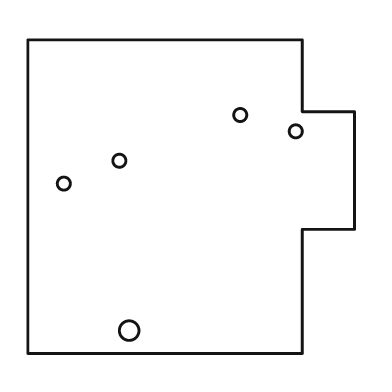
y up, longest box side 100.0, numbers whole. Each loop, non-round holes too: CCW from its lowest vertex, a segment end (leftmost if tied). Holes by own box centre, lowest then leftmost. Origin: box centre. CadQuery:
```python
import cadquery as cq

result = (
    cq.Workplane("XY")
    .moveTo(-50.0, -48.0)
    .lineTo(34.0, -48.0)
    .lineTo(34.0, -10.0)
    .lineTo(50.0, -10.0)
    .lineTo(50.0, 26.0)
    .lineTo(34.0, 26.0)
    .lineTo(34.0, 48.0)
    .lineTo(-50.0, 48.0)
    .close()
    .moveTo(-19.0, -41.0)
    .circle(3.0)
    .moveTo(-39.0, 4.0)
    .circle(2.0)
    .moveTo(-22.0, 11.0)
    .circle(2.0)
    .moveTo(32.0, 20.0)
    .circle(2.0)
    .moveTo(15.0, 25.0)
    .circle(2.0)
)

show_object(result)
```